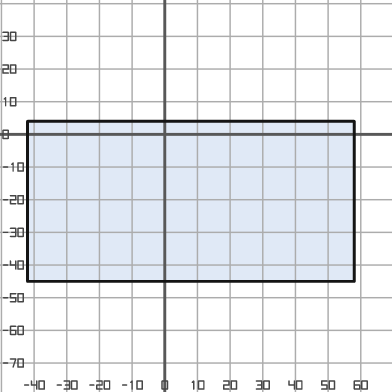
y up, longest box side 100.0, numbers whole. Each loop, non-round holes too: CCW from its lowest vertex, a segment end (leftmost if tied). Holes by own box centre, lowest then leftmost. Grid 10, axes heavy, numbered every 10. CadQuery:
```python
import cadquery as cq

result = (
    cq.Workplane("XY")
    .moveTo(-42.0, -45.0)
    .lineTo(58.0, -45.0)
    .lineTo(58.0, 4.0)
    .lineTo(-42.0, 4.0)
    .close()
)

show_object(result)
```